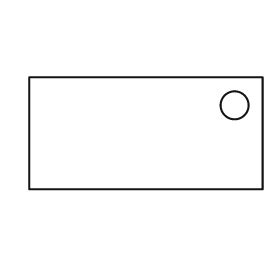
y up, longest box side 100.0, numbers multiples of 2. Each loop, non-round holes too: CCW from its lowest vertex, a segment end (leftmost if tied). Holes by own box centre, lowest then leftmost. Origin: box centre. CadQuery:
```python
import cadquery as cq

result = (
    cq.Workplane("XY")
    .moveTo(-50.0, -24.0)
    .lineTo(50.0, -24.0)
    .lineTo(50.0, 24.0)
    .lineTo(-50.0, 24.0)
    .close()
    .moveTo(38.0, 12.0)
    .circle(6.0)
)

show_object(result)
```